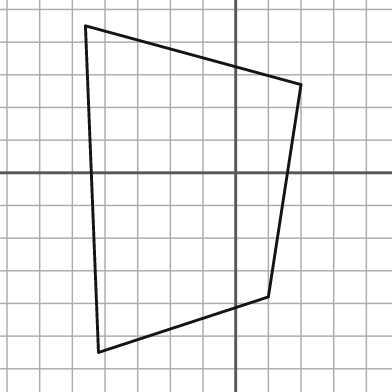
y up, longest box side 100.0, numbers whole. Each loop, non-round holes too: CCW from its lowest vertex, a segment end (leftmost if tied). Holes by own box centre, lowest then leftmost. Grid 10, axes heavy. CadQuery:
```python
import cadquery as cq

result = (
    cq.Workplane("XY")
    .moveTo(-42.0, -55.0)
    .lineTo(10.0, -38.0)
    .lineTo(20.0, 27.0)
    .lineTo(-46.0, 45.0)
    .close()
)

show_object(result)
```